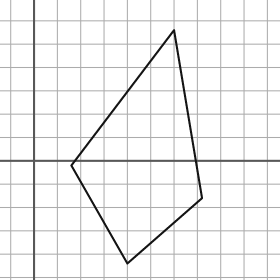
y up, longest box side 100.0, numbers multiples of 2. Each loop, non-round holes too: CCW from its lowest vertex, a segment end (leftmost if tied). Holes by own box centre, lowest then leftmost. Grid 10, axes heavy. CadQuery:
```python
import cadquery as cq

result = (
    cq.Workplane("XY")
    .moveTo(40.0, -44.0)
    .lineTo(72.0, -16.0)
    .lineTo(60.0, 56.0)
    .lineTo(16.0, -2.0)
    .close()
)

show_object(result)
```